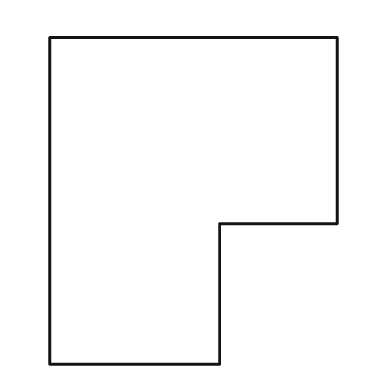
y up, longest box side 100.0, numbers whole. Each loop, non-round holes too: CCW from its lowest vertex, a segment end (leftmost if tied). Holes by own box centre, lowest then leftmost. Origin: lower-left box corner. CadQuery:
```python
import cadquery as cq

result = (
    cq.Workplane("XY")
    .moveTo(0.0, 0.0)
    .lineTo(52.0, 0.0)
    .lineTo(52.0, 43.0)
    .lineTo(88.0, 43.0)
    .lineTo(88.0, 100.0)
    .lineTo(0.0, 100.0)
    .close()
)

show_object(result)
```